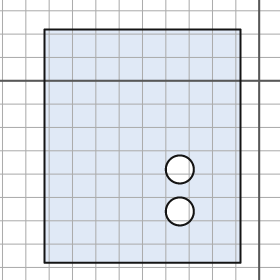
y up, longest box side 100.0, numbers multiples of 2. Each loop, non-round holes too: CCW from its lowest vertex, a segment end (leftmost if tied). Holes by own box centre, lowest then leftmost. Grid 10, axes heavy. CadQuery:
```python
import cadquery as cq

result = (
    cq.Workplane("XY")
    .moveTo(-92.0, -78.0)
    .lineTo(-8.0, -78.0)
    .lineTo(-8.0, 22.0)
    .lineTo(-92.0, 22.0)
    .close()
    .moveTo(-34.0, -56.0)
    .circle(6.0)
    .moveTo(-34.0, -38.0)
    .circle(6.0)
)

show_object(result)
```